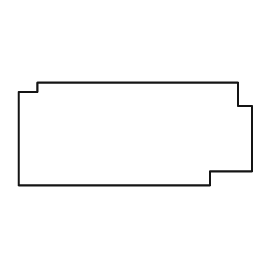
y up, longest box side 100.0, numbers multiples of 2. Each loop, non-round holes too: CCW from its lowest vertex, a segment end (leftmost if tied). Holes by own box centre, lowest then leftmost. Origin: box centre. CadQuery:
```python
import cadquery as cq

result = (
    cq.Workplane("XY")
    .moveTo(-50.0, -22.0)
    .lineTo(32.0, -22.0)
    .lineTo(32.0, -16.0)
    .lineTo(50.0, -16.0)
    .lineTo(50.0, 12.0)
    .lineTo(44.0, 12.0)
    .lineTo(44.0, 22.0)
    .lineTo(-42.0, 22.0)
    .lineTo(-42.0, 18.0)
    .lineTo(-50.0, 18.0)
    .close()
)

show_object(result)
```